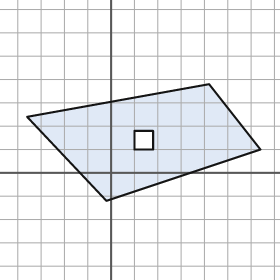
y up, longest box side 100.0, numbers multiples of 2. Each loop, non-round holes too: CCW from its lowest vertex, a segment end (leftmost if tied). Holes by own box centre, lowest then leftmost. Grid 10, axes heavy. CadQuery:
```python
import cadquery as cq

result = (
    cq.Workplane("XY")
    .moveTo(-2.0, -12.0)
    .lineTo(64.0, 10.0)
    .lineTo(42.0, 38.0)
    .lineTo(-36.0, 24.0)
    .close()
    .moveTo(10.0, 10.0)
    .lineTo(18.0, 10.0)
    .lineTo(18.0, 18.0)
    .lineTo(10.0, 18.0)
    .close()
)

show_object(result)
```